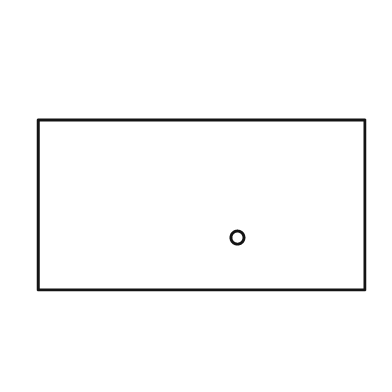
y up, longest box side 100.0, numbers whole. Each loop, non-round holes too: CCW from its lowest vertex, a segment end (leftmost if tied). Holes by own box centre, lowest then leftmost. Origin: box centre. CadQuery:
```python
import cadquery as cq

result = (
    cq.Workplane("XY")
    .moveTo(-50.0, -26.0)
    .lineTo(50.0, -26.0)
    .lineTo(50.0, 26.0)
    .lineTo(-50.0, 26.0)
    .close()
    .moveTo(11.0, -10.0)
    .circle(2.0)
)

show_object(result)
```